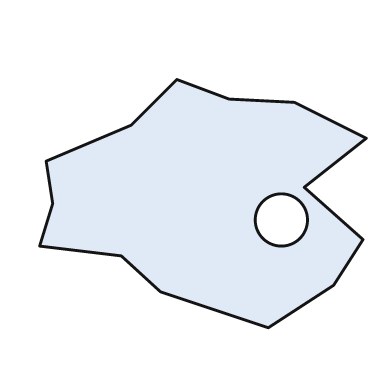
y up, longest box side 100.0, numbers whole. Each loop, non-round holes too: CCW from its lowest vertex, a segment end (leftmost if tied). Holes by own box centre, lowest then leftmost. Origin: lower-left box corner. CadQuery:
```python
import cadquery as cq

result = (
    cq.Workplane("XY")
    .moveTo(70.0, 0.0)
    .lineTo(90.0, 13.0)
    .lineTo(99.0, 27.0)
    .lineTo(81.0, 43.0)
    .lineTo(100.0, 58.0)
    .lineTo(78.0, 69.0)
    .lineTo(58.0, 70.0)
    .lineTo(42.0, 76.0)
    .lineTo(28.0, 62.0)
    .lineTo(2.0, 51.0)
    .lineTo(4.0, 38.0)
    .lineTo(0.0, 25.0)
    .lineTo(25.0, 22.0)
    .lineTo(37.0, 11.0)
    .close()
    .moveTo(74.0, 33.0)
    .circle(8.0)
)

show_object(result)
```